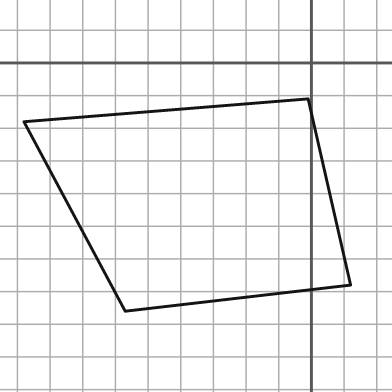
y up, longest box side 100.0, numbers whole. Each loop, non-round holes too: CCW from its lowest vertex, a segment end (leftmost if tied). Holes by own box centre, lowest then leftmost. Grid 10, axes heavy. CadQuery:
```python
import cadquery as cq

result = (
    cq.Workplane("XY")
    .moveTo(-57.0, -76.0)
    .lineTo(12.0, -68.0)
    .lineTo(-1.0, -11.0)
    .lineTo(-88.0, -18.0)
    .close()
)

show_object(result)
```